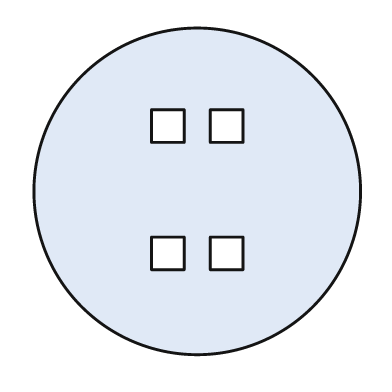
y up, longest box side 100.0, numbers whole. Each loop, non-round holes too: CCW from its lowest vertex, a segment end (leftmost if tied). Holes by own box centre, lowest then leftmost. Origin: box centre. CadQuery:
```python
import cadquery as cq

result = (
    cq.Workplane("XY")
    .moveTo(0.0, 0.0)
    .circle(50.0)
    .moveTo(-14.0, -24.0)
    .lineTo(-4.0, -24.0)
    .lineTo(-4.0, -14.0)
    .lineTo(-14.0, -14.0)
    .close()
    .moveTo(4.0, -24.0)
    .lineTo(14.0, -24.0)
    .lineTo(14.0, -14.0)
    .lineTo(4.0, -14.0)
    .close()
    .moveTo(-14.0, 15.0)
    .lineTo(-4.0, 15.0)
    .lineTo(-4.0, 25.0)
    .lineTo(-14.0, 25.0)
    .close()
    .moveTo(4.0, 15.0)
    .lineTo(14.0, 15.0)
    .lineTo(14.0, 25.0)
    .lineTo(4.0, 25.0)
    .close()
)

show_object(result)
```